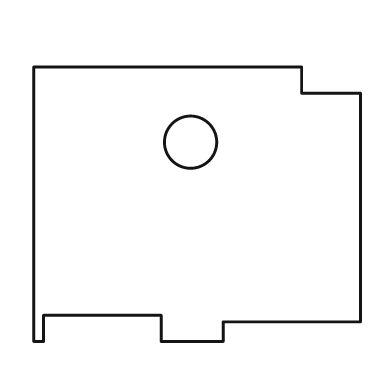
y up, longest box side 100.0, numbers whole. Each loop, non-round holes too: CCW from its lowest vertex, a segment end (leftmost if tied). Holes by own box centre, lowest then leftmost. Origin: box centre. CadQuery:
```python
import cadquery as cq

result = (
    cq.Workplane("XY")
    .moveTo(-50.0, -42.0)
    .lineTo(-47.0, -42.0)
    .lineTo(-47.0, -34.0)
    .lineTo(-11.0, -34.0)
    .lineTo(-11.0, -42.0)
    .lineTo(8.0, -42.0)
    .lineTo(8.0, -36.0)
    .lineTo(50.0, -36.0)
    .lineTo(50.0, 34.0)
    .lineTo(32.0, 34.0)
    .lineTo(32.0, 42.0)
    .lineTo(-50.0, 42.0)
    .close()
    .moveTo(-2.0, 19.0)
    .circle(8.0)
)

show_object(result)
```